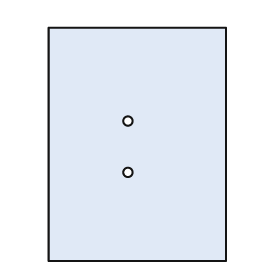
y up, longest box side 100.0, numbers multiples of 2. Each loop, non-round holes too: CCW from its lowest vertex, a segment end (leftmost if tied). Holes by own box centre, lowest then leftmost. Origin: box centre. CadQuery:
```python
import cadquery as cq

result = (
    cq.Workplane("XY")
    .moveTo(-38.0, -50.0)
    .lineTo(38.0, -50.0)
    .lineTo(38.0, 50.0)
    .lineTo(-38.0, 50.0)
    .close()
    .moveTo(-4.0, -12.0)
    .circle(2.0)
    .moveTo(-4.0, 10.0)
    .circle(2.0)
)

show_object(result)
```